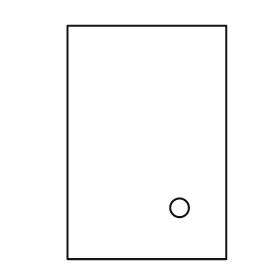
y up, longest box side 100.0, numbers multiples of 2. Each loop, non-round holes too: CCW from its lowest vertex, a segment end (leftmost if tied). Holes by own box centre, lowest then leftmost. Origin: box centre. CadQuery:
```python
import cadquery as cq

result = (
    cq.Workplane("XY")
    .moveTo(-34.0, -50.0)
    .lineTo(34.0, -50.0)
    .lineTo(34.0, 50.0)
    .lineTo(-34.0, 50.0)
    .close()
    .moveTo(14.0, -28.0)
    .circle(4.0)
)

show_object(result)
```